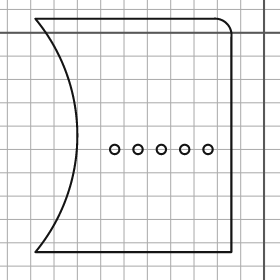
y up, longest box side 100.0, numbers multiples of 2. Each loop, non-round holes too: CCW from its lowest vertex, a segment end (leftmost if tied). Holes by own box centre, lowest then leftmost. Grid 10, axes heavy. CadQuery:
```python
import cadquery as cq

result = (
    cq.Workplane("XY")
    .moveTo(-98.0, -94.0)
    .lineTo(-14.0, -94.0)
    .lineTo(-14.0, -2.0)
    .threePointArc((-16.0, 4.0), (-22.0, 6.0))
    .lineTo(-98.0, 6.0)
    .threePointArc((-80.0, -44.0), (-98.0, -94.0))
    .close()
    .moveTo(-64.0, -50.0)
    .circle(2.0)
    .moveTo(-54.0, -50.0)
    .circle(2.0)
    .moveTo(-44.0, -50.0)
    .circle(2.0)
    .moveTo(-34.0, -50.0)
    .circle(2.0)
    .moveTo(-24.0, -50.0)
    .circle(2.0)
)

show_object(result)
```